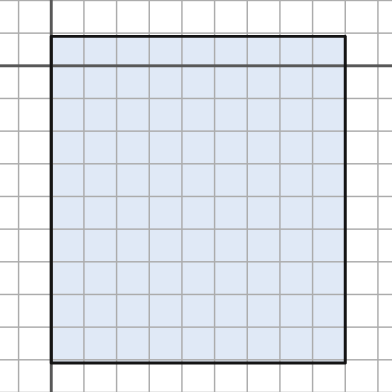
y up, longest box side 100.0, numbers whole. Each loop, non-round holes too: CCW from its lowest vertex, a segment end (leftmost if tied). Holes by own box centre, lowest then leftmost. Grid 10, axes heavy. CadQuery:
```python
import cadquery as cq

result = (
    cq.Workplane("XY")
    .moveTo(0.0, -91.0)
    .lineTo(90.0, -91.0)
    .lineTo(90.0, 9.0)
    .lineTo(0.0, 9.0)
    .close()
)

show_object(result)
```